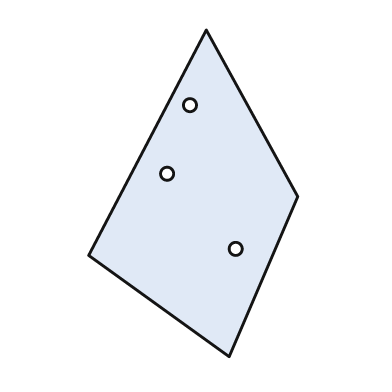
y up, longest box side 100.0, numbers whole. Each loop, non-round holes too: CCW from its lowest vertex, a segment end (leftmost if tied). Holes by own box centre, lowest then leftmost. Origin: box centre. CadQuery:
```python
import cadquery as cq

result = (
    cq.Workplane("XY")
    .moveTo(11.0, -50.0)
    .lineTo(32.0, -1.0)
    .lineTo(4.0, 50.0)
    .lineTo(-32.0, -19.0)
    .close()
    .moveTo(13.0, -17.0)
    .circle(2.0)
    .moveTo(-8.0, 6.0)
    .circle(2.0)
    .moveTo(-1.0, 27.0)
    .circle(2.0)
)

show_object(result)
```